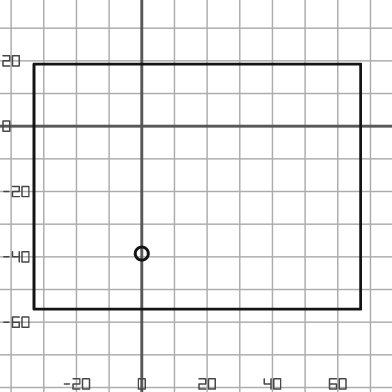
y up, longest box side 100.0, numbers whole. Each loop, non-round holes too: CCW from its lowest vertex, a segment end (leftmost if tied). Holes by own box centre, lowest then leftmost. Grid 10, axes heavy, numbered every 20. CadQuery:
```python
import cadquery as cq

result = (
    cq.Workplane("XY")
    .moveTo(-33.0, -56.0)
    .lineTo(67.0, -56.0)
    .lineTo(67.0, 19.0)
    .lineTo(-33.0, 19.0)
    .close()
    .moveTo(0.0, -39.0)
    .circle(2.0)
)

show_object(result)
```